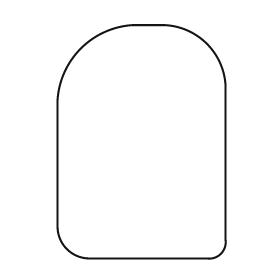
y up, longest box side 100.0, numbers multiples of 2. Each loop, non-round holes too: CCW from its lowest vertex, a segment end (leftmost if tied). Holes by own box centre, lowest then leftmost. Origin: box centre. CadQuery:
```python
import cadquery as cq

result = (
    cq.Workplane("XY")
    .moveTo(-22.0, -50.0)
    .lineTo(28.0, -50.0)
    .threePointArc((34.0, -48.0), (36.0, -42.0))
    .lineTo(36.0, 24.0)
    .threePointArc((28.0, 42.0), (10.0, 50.0))
    .lineTo(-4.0, 50.0)
    .threePointArc((-26.0, 40.0), (-36.0, 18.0))
    .lineTo(-36.0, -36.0)
    .threePointArc((-32.0, -46.0), (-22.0, -50.0))
    .close()
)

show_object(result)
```